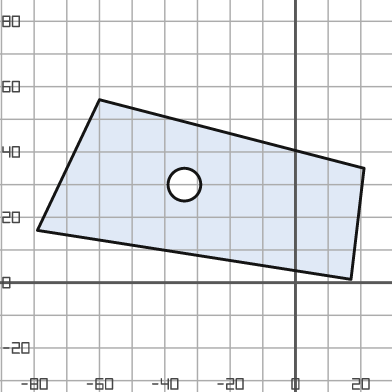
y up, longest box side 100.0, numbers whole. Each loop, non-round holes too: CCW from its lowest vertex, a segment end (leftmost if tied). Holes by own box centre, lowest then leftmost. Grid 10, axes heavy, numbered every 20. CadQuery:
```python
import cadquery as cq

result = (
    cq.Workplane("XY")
    .moveTo(17.0, 1.0)
    .lineTo(21.0, 35.0)
    .lineTo(-60.0, 56.0)
    .lineTo(-79.0, 16.0)
    .close()
    .moveTo(-34.0, 30.0)
    .circle(5.0)
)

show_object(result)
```